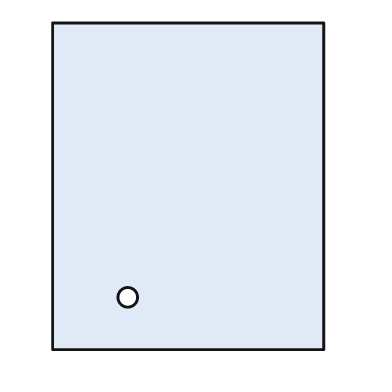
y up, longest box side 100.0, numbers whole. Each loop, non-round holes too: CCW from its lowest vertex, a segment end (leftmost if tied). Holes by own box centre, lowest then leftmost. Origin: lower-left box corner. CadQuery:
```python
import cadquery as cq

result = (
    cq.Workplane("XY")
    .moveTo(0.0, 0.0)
    .lineTo(83.0, 0.0)
    .lineTo(83.0, 100.0)
    .lineTo(0.0, 100.0)
    .close()
    .moveTo(23.0, 16.0)
    .circle(3.0)
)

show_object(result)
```